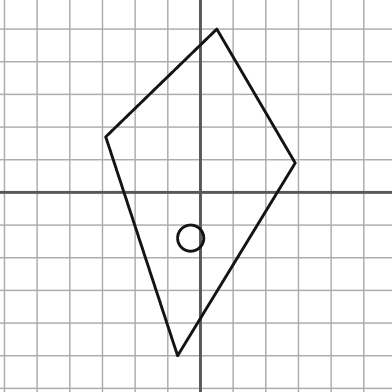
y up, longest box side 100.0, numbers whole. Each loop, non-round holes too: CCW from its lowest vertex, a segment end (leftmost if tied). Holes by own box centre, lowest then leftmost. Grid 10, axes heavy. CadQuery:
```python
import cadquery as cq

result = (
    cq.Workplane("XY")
    .moveTo(-7.0, -50.0)
    .lineTo(29.0, 9.0)
    .lineTo(5.0, 50.0)
    .lineTo(-29.0, 17.0)
    .close()
    .moveTo(-3.0, -14.0)
    .circle(4.0)
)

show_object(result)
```